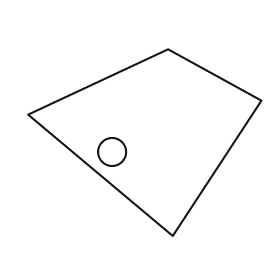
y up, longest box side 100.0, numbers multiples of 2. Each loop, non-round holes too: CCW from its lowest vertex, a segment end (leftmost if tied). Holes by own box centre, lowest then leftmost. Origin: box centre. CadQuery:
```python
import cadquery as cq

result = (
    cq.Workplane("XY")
    .moveTo(12.0, -40.0)
    .lineTo(50.0, 18.0)
    .lineTo(10.0, 40.0)
    .lineTo(-50.0, 12.0)
    .close()
    .moveTo(-14.0, -4.0)
    .circle(6.0)
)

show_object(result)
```